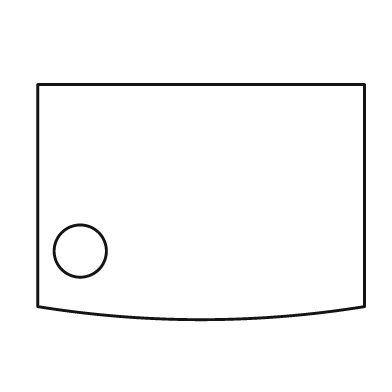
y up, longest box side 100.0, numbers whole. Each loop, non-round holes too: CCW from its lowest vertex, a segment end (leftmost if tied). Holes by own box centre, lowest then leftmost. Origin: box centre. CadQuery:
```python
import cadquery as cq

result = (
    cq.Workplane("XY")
    .moveTo(-50.0, -32.0)
    .threePointArc((0.0, -36.0), (50.0, -32.0))
    .lineTo(50.0, 36.0)
    .lineTo(-50.0, 36.0)
    .close()
    .moveTo(-37.0, -15.0)
    .circle(8.0)
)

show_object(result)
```